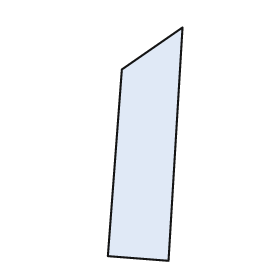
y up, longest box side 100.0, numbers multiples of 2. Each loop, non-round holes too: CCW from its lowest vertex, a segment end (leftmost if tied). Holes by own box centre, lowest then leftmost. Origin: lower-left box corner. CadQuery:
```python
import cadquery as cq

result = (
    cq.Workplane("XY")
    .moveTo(26.0, 0.0)
    .lineTo(32.0, 100.0)
    .lineTo(6.0, 82.0)
    .lineTo(0.0, 2.0)
    .close()
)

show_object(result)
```